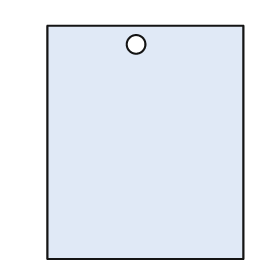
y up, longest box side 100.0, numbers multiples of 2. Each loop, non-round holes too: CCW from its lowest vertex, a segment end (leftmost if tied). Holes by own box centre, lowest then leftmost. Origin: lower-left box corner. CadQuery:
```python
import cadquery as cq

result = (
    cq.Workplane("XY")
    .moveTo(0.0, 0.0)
    .lineTo(84.0, 0.0)
    .lineTo(84.0, 100.0)
    .lineTo(0.0, 100.0)
    .close()
    .moveTo(38.0, 92.0)
    .circle(4.0)
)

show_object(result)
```